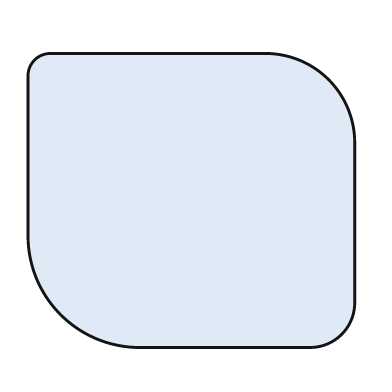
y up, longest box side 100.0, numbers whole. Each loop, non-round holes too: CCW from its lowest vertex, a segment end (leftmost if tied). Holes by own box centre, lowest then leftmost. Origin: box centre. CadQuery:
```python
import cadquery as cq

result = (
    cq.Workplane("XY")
    .moveTo(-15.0, -45.0)
    .lineTo(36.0, -45.0)
    .threePointArc((46.0, -41.0), (50.0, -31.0))
    .lineTo(50.0, 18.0)
    .threePointArc((42.0, 37.0), (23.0, 45.0))
    .lineTo(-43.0, 45.0)
    .threePointArc((-48.0, 43.0), (-50.0, 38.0))
    .lineTo(-50.0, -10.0)
    .threePointArc((-40.0, -35.0), (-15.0, -45.0))
    .close()
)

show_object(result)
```